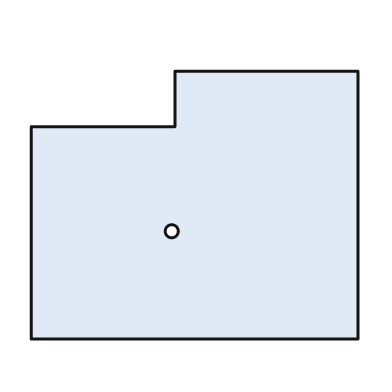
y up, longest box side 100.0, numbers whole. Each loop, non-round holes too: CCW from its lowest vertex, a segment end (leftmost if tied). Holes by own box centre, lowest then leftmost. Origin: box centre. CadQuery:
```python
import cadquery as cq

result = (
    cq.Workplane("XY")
    .moveTo(-50.0, -41.0)
    .lineTo(50.0, -41.0)
    .lineTo(50.0, 41.0)
    .lineTo(-6.0, 41.0)
    .lineTo(-6.0, 24.0)
    .lineTo(-50.0, 24.0)
    .close()
    .moveTo(-7.0, -8.0)
    .circle(2.0)
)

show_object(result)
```